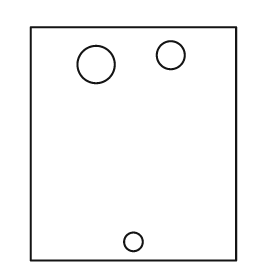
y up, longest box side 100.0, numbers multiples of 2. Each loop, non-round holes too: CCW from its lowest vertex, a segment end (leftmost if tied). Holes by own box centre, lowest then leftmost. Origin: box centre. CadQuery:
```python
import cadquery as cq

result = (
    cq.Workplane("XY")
    .moveTo(-44.0, -50.0)
    .lineTo(44.0, -50.0)
    .lineTo(44.0, 50.0)
    .lineTo(-44.0, 50.0)
    .close()
    .moveTo(0.0, -42.0)
    .circle(4.0)
    .moveTo(-16.0, 34.0)
    .circle(8.0)
    .moveTo(16.0, 38.0)
    .circle(6.0)
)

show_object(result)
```